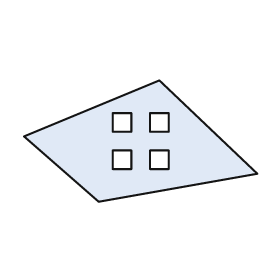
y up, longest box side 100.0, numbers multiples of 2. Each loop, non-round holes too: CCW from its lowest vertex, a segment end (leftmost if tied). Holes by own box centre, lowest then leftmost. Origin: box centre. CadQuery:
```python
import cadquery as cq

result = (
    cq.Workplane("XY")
    .moveTo(-18.0, -26.0)
    .lineTo(50.0, -14.0)
    .lineTo(8.0, 26.0)
    .lineTo(-50.0, 2.0)
    .close()
    .moveTo(-12.0, -12.0)
    .lineTo(-4.0, -12.0)
    .lineTo(-4.0, -4.0)
    .lineTo(-12.0, -4.0)
    .close()
    .moveTo(4.0, -12.0)
    .lineTo(12.0, -12.0)
    .lineTo(12.0, -4.0)
    .lineTo(4.0, -4.0)
    .close()
    .moveTo(-12.0, 4.0)
    .lineTo(-4.0, 4.0)
    .lineTo(-4.0, 12.0)
    .lineTo(-12.0, 12.0)
    .close()
    .moveTo(4.0, 4.0)
    .lineTo(12.0, 4.0)
    .lineTo(12.0, 12.0)
    .lineTo(4.0, 12.0)
    .close()
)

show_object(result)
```